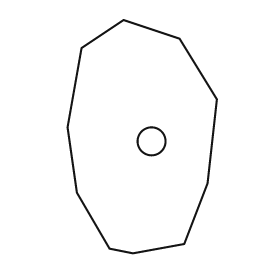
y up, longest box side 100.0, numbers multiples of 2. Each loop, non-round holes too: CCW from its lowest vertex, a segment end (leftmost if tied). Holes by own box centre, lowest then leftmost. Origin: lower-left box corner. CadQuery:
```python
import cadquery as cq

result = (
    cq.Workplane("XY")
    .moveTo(28.0, 0.0)
    .lineTo(50.0, 4.0)
    .lineTo(60.0, 30.0)
    .lineTo(64.0, 66.0)
    .lineTo(48.0, 92.0)
    .lineTo(24.0, 100.0)
    .lineTo(6.0, 88.0)
    .lineTo(0.0, 54.0)
    .lineTo(4.0, 26.0)
    .lineTo(18.0, 2.0)
    .close()
    .moveTo(36.0, 48.0)
    .circle(6.0)
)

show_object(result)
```